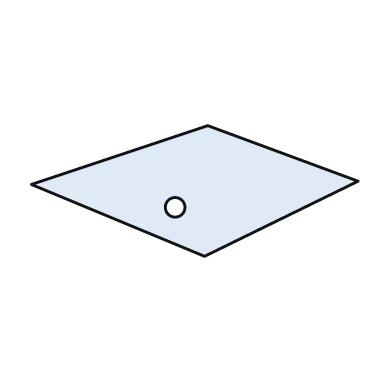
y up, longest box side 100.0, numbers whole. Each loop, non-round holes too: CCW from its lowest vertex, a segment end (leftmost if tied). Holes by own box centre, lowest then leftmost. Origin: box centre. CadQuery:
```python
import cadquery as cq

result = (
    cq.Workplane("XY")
    .moveTo(3.0, -20.0)
    .lineTo(50.0, 3.0)
    .lineTo(4.0, 20.0)
    .lineTo(-50.0, 2.0)
    .close()
    .moveTo(-6.0, -5.0)
    .circle(3.0)
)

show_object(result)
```